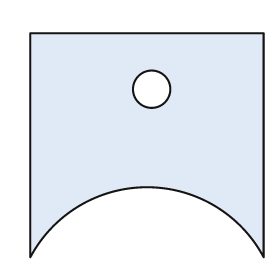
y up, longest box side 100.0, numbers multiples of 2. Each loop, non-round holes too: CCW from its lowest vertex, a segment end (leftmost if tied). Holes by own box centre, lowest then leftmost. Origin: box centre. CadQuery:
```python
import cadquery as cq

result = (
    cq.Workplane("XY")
    .moveTo(-50.0, -48.0)
    .threePointArc((0.0, -18.0), (50.0, -48.0))
    .lineTo(50.0, 48.0)
    .lineTo(-50.0, 48.0)
    .close()
    .moveTo(2.0, 24.0)
    .circle(8.0)
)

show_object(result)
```